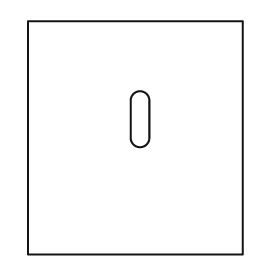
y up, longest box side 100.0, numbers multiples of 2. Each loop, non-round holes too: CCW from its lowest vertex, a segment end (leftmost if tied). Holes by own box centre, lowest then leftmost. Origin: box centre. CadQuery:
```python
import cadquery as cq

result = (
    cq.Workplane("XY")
    .moveTo(-46.0, -50.0)
    .lineTo(46.0, -50.0)
    .lineTo(46.0, 50.0)
    .lineTo(-46.0, 50.0)
    .close()
    .moveTo(-2.0, 0.0)
    .threePointArc((2.0, -4.0), (6.0, 0.0))
    .lineTo(6.0, 16.0)
    .threePointArc((2.0, 20.0), (-2.0, 16.0))
    .close()
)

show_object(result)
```